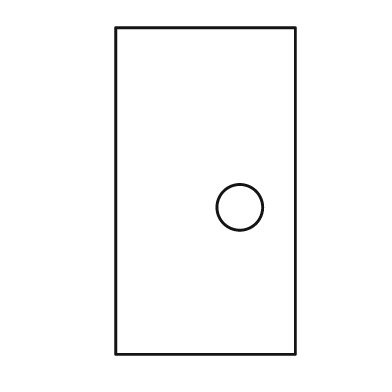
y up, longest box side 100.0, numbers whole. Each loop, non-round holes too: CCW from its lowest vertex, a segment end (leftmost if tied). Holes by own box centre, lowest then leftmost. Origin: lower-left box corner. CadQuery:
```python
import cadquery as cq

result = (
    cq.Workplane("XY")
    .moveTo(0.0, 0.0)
    .lineTo(55.0, 0.0)
    .lineTo(55.0, 100.0)
    .lineTo(0.0, 100.0)
    .close()
    .moveTo(38.0, 45.0)
    .circle(7.0)
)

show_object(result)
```